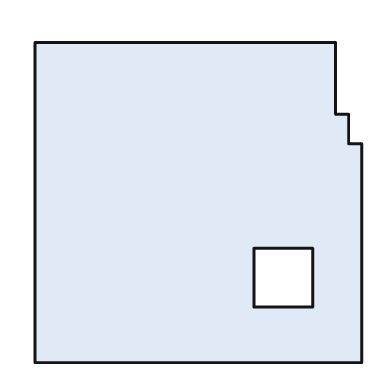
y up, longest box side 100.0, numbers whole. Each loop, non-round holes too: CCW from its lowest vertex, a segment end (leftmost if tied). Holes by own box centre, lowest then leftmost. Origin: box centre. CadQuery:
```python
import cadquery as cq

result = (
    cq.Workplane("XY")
    .moveTo(-50.0, -49.0)
    .lineTo(50.0, -49.0)
    .lineTo(50.0, 18.0)
    .lineTo(46.0, 18.0)
    .lineTo(46.0, 27.0)
    .lineTo(42.0, 27.0)
    .lineTo(42.0, 49.0)
    .lineTo(-50.0, 49.0)
    .close()
    .moveTo(17.0, -32.0)
    .lineTo(35.0, -32.0)
    .lineTo(35.0, -14.0)
    .lineTo(17.0, -14.0)
    .close()
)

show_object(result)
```